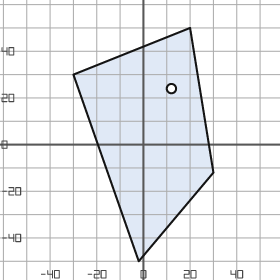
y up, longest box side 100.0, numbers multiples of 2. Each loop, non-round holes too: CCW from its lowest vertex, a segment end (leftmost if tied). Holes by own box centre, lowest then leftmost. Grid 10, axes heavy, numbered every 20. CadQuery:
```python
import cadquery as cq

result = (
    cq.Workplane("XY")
    .moveTo(-2.0, -50.0)
    .lineTo(30.0, -12.0)
    .lineTo(20.0, 50.0)
    .lineTo(-30.0, 30.0)
    .close()
    .moveTo(12.0, 24.0)
    .circle(2.0)
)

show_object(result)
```